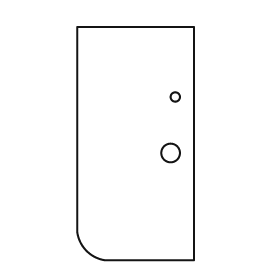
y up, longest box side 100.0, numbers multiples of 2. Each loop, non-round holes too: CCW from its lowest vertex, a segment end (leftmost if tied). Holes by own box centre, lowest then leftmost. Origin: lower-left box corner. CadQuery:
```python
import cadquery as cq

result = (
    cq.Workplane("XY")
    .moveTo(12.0, 0.0)
    .lineTo(50.0, 0.0)
    .lineTo(50.0, 100.0)
    .lineTo(0.0, 100.0)
    .lineTo(0.0, 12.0)
    .threePointArc((4.0, 4.0), (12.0, 0.0))
    .close()
    .moveTo(40.0, 46.0)
    .circle(4.0)
    .moveTo(42.0, 70.0)
    .circle(2.0)
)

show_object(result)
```